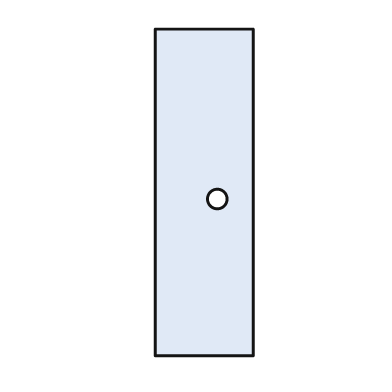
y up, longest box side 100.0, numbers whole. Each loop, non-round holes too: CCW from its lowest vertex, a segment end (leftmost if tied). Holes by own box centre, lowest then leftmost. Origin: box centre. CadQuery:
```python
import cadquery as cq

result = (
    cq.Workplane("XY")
    .moveTo(-15.0, -50.0)
    .lineTo(15.0, -50.0)
    .lineTo(15.0, 50.0)
    .lineTo(-15.0, 50.0)
    .close()
    .moveTo(4.0, -2.0)
    .circle(3.0)
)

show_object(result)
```